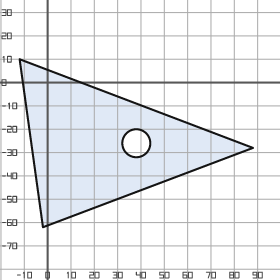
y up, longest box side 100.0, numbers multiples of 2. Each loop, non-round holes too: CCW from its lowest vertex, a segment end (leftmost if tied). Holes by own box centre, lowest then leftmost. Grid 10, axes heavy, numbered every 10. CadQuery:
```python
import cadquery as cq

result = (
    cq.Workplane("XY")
    .moveTo(-2.0, -62.0)
    .lineTo(88.0, -28.0)
    .lineTo(-12.0, 10.0)
    .close()
    .moveTo(38.0, -26.0)
    .circle(6.0)
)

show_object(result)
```